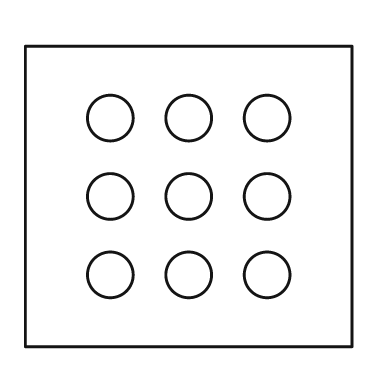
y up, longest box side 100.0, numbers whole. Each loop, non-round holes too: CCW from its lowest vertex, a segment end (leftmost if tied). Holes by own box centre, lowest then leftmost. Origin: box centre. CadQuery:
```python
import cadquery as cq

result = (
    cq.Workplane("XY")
    .moveTo(-50.0, -46.0)
    .lineTo(50.0, -46.0)
    .lineTo(50.0, 46.0)
    .lineTo(-50.0, 46.0)
    .close()
    .moveTo(-24.0, -24.0)
    .circle(7.0)
    .moveTo(0.0, -24.0)
    .circle(7.0)
    .moveTo(24.0, -24.0)
    .circle(7.0)
    .moveTo(-24.0, 0.0)
    .circle(7.0)
    .moveTo(0.0, 0.0)
    .circle(7.0)
    .moveTo(24.0, 0.0)
    .circle(7.0)
    .moveTo(-24.0, 24.0)
    .circle(7.0)
    .moveTo(0.0, 24.0)
    .circle(7.0)
    .moveTo(24.0, 24.0)
    .circle(7.0)
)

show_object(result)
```